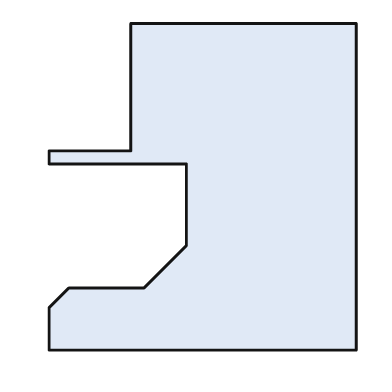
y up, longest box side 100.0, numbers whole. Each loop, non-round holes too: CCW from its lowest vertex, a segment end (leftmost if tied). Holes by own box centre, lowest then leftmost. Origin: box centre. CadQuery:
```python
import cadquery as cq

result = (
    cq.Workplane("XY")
    .moveTo(-47.0, -50.0)
    .lineTo(47.0, -50.0)
    .lineTo(47.0, 50.0)
    .lineTo(-22.0, 50.0)
    .lineTo(-22.0, 11.0)
    .lineTo(-47.0, 11.0)
    .lineTo(-47.0, 7.0)
    .lineTo(-5.0, 7.0)
    .lineTo(-5.0, -18.0)
    .lineTo(-18.0, -31.0)
    .lineTo(-41.0, -31.0)
    .lineTo(-47.0, -37.0)
    .close()
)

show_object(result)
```